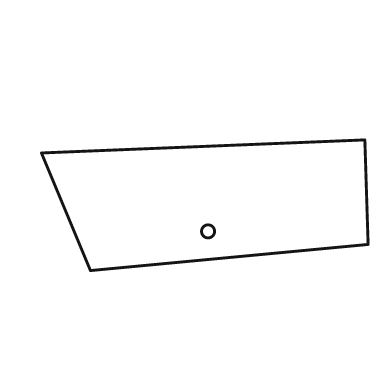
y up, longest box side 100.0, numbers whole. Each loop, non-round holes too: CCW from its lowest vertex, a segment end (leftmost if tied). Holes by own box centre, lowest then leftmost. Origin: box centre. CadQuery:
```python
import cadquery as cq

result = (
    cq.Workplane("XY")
    .moveTo(-35.0, -20.0)
    .lineTo(50.0, -12.0)
    .lineTo(49.0, 20.0)
    .lineTo(-50.0, 16.0)
    .close()
    .moveTo(1.0, -8.0)
    .circle(2.0)
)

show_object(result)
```